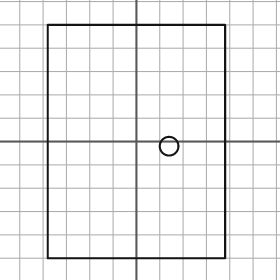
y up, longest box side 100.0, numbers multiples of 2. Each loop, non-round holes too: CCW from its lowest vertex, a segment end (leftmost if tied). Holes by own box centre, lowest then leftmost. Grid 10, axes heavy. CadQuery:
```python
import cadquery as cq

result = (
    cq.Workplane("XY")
    .moveTo(-38.0, -50.0)
    .lineTo(38.0, -50.0)
    .lineTo(38.0, 50.0)
    .lineTo(-38.0, 50.0)
    .close()
    .moveTo(14.0, -2.0)
    .circle(4.0)
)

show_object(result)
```